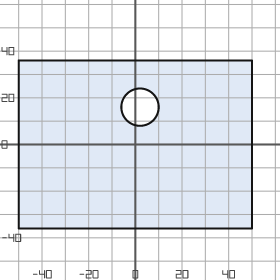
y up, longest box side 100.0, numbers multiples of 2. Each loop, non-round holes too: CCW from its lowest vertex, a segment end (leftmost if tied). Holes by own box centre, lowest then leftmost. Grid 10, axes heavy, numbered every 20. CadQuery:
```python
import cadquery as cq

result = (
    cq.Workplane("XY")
    .moveTo(-50.0, -36.0)
    .lineTo(50.0, -36.0)
    .lineTo(50.0, 36.0)
    .lineTo(-50.0, 36.0)
    .close()
    .moveTo(2.0, 16.0)
    .circle(8.0)
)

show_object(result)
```